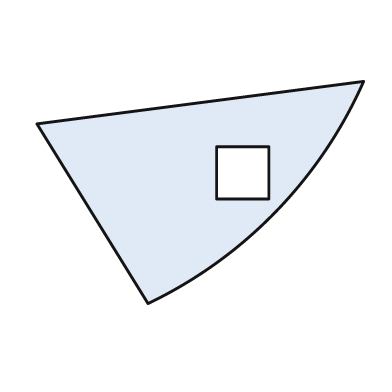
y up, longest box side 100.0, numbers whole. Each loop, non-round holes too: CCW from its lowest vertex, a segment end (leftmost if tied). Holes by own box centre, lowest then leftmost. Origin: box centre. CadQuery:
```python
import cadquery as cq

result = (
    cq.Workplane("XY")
    .moveTo(-16.0, -34.0)
    .threePointArc((23.0, -6.0), (50.0, 34.0))
    .lineTo(-50.0, 21.0)
    .close()
    .moveTo(5.0, -2.0)
    .lineTo(21.0, -2.0)
    .lineTo(21.0, 14.0)
    .lineTo(5.0, 14.0)
    .close()
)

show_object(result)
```